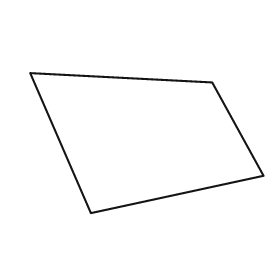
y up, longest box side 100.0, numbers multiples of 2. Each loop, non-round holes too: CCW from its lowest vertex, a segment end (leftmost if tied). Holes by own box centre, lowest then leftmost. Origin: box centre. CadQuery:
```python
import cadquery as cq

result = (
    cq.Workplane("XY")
    .moveTo(-24.0, -30.0)
    .lineTo(50.0, -14.0)
    .lineTo(28.0, 26.0)
    .lineTo(-50.0, 30.0)
    .close()
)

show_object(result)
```